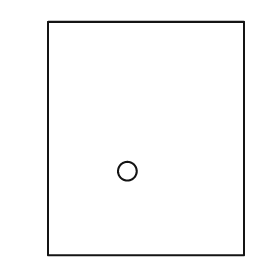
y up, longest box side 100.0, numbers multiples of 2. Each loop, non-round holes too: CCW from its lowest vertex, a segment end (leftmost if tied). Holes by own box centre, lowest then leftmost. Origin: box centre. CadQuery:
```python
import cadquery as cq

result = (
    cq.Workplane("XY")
    .moveTo(-42.0, -50.0)
    .lineTo(42.0, -50.0)
    .lineTo(42.0, 50.0)
    .lineTo(-42.0, 50.0)
    .close()
    .moveTo(-8.0, -14.0)
    .circle(4.0)
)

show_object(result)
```